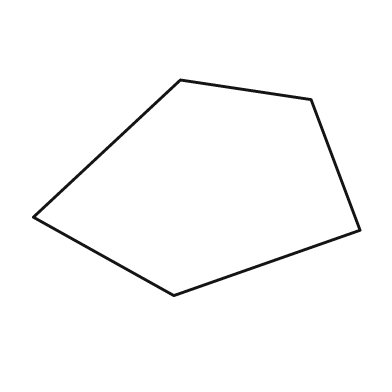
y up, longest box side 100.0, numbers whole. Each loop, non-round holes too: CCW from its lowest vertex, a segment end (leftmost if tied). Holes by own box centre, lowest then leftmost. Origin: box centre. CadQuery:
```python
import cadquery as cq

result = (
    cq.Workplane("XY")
    .moveTo(-7.0, -33.0)
    .lineTo(50.0, -13.0)
    .lineTo(35.0, 27.0)
    .lineTo(-5.0, 33.0)
    .lineTo(-50.0, -9.0)
    .close()
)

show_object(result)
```